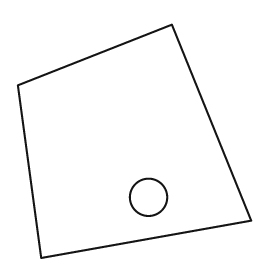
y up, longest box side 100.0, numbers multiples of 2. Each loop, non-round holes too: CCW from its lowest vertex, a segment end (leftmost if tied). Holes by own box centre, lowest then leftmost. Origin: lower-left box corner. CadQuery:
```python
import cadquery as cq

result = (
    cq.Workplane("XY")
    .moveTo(10.0, 0.0)
    .lineTo(100.0, 16.0)
    .lineTo(66.0, 100.0)
    .lineTo(0.0, 74.0)
    .close()
    .moveTo(56.0, 26.0)
    .circle(8.0)
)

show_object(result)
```